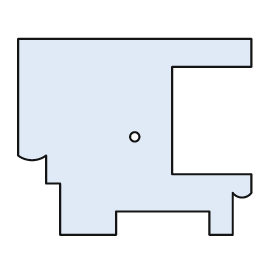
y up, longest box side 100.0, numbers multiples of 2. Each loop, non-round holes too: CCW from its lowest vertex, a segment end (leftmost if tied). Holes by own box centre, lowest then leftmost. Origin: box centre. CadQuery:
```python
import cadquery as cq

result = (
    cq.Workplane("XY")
    .moveTo(-32.0, -42.0)
    .lineTo(-8.0, -42.0)
    .lineTo(-8.0, -32.0)
    .lineTo(32.0, -32.0)
    .lineTo(32.0, -42.0)
    .lineTo(42.0, -42.0)
    .lineTo(42.0, -24.0)
    .threePointArc((46.0, -26.0), (50.0, -24.0))
    .lineTo(50.0, -16.0)
    .lineTo(16.0, -16.0)
    .lineTo(16.0, 30.0)
    .lineTo(50.0, 30.0)
    .lineTo(50.0, 42.0)
    .lineTo(-50.0, 42.0)
    .lineTo(-50.0, -8.0)
    .threePointArc((-44.0, -10.0), (-38.0, -8.0))
    .lineTo(-38.0, -20.0)
    .lineTo(-32.0, -20.0)
    .close()
    .moveTo(0.0, 0.0)
    .circle(2.0)
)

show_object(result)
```